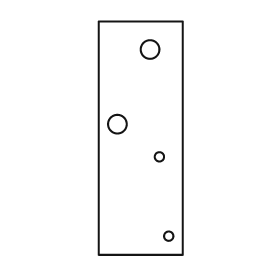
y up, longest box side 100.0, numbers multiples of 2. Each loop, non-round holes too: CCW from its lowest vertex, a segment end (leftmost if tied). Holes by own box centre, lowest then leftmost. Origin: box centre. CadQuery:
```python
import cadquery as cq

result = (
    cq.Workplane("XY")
    .moveTo(-18.0, -50.0)
    .lineTo(18.0, -50.0)
    .lineTo(18.0, 50.0)
    .lineTo(-18.0, 50.0)
    .close()
    .moveTo(12.0, -42.0)
    .circle(2.0)
    .moveTo(8.0, -8.0)
    .circle(2.0)
    .moveTo(-10.0, 6.0)
    .circle(4.0)
    .moveTo(4.0, 38.0)
    .circle(4.0)
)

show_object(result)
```